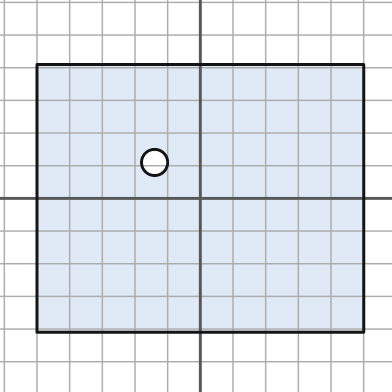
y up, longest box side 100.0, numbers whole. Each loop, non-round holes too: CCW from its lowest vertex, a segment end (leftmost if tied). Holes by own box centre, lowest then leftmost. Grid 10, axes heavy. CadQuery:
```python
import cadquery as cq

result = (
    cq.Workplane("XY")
    .moveTo(-50.0, -41.0)
    .lineTo(50.0, -41.0)
    .lineTo(50.0, 41.0)
    .lineTo(-50.0, 41.0)
    .close()
    .moveTo(-14.0, 11.0)
    .circle(4.0)
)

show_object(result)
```